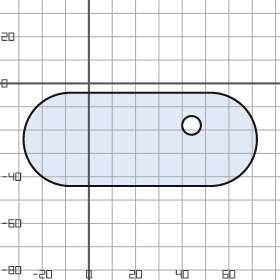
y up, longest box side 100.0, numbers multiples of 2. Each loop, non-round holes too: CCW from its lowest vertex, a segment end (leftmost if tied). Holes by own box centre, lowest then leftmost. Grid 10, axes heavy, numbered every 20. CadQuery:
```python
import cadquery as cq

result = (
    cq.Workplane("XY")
    .moveTo(-8.0, -44.0)
    .lineTo(52.0, -44.0)
    .threePointArc((72.0, -24.0), (52.0, -4.0))
    .lineTo(-8.0, -4.0)
    .threePointArc((-28.0, -24.0), (-8.0, -44.0))
    .close()
    .moveTo(44.0, -18.0)
    .circle(4.0)
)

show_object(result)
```